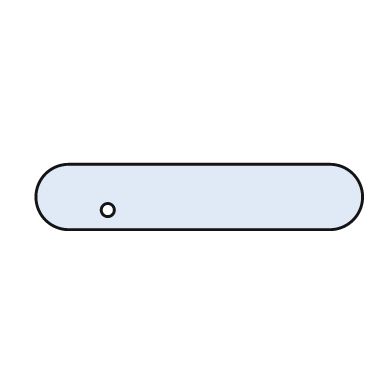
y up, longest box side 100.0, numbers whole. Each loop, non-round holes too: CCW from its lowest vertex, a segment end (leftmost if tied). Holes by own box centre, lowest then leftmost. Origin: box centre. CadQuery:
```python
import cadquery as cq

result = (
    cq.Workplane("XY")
    .moveTo(-40.0, -10.0)
    .lineTo(40.0, -10.0)
    .threePointArc((50.0, 0.0), (40.0, 10.0))
    .lineTo(-40.0, 10.0)
    .threePointArc((-50.0, 0.0), (-40.0, -10.0))
    .close()
    .moveTo(-28.0, -4.0)
    .circle(2.0)
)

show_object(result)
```